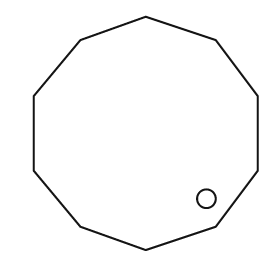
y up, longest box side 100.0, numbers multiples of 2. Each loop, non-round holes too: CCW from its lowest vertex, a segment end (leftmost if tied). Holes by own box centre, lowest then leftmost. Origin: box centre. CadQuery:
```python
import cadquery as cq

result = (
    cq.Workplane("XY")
    .moveTo(0.0, -50.0)
    .lineTo(30.0, -40.0)
    .lineTo(48.0, -16.0)
    .lineTo(48.0, 16.0)
    .lineTo(30.0, 40.0)
    .lineTo(0.0, 50.0)
    .lineTo(-28.0, 40.0)
    .lineTo(-48.0, 16.0)
    .lineTo(-48.0, -16.0)
    .lineTo(-28.0, -40.0)
    .close()
    .moveTo(26.0, -28.0)
    .circle(4.0)
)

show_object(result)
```